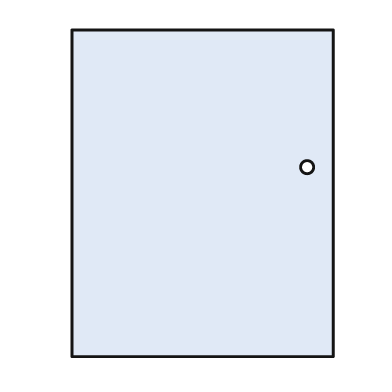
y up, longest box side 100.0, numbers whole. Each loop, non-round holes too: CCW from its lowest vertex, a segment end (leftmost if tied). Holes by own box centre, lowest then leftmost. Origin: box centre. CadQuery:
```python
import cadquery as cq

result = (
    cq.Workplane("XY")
    .moveTo(-40.0, -50.0)
    .lineTo(40.0, -50.0)
    .lineTo(40.0, 50.0)
    .lineTo(-40.0, 50.0)
    .close()
    .moveTo(32.0, 8.0)
    .circle(2.0)
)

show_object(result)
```